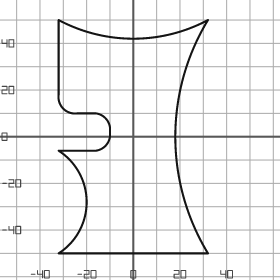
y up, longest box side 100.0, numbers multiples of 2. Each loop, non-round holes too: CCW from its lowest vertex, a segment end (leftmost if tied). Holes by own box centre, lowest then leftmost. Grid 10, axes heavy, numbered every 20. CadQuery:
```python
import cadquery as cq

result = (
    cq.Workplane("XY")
    .moveTo(-32.0, -50.0)
    .lineTo(32.0, -50.0)
    .threePointArc((18.0, 0.0), (32.0, 50.0))
    .threePointArc((0.0, 42.0), (-32.0, 50.0))
    .lineTo(-32.0, 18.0)
    .threePointArc((-30.0, 12.0), (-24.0, 10.0))
    .lineTo(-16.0, 10.0)
    .threePointArc((-12.0, 8.0), (-10.0, 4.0))
    .lineTo(-10.0, 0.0)
    .threePointArc((-12.0, -4.0), (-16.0, -6.0))
    .lineTo(-32.0, -6.0)
    .threePointArc((-20.0, -28.0), (-32.0, -50.0))
    .close()
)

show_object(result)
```